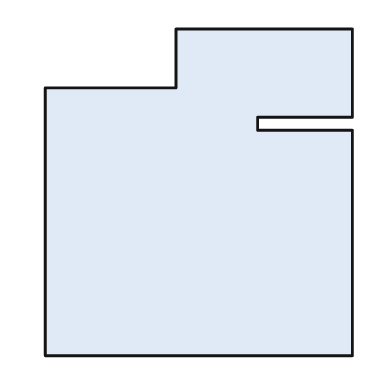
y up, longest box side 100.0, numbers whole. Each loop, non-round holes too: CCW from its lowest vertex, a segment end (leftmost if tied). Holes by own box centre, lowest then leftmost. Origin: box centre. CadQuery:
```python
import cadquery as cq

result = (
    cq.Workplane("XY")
    .moveTo(-47.0, -50.0)
    .lineTo(47.0, -50.0)
    .lineTo(47.0, 19.0)
    .lineTo(18.0, 19.0)
    .lineTo(18.0, 23.0)
    .lineTo(47.0, 23.0)
    .lineTo(47.0, 50.0)
    .lineTo(-7.0, 50.0)
    .lineTo(-7.0, 32.0)
    .lineTo(-47.0, 32.0)
    .close()
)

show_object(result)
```